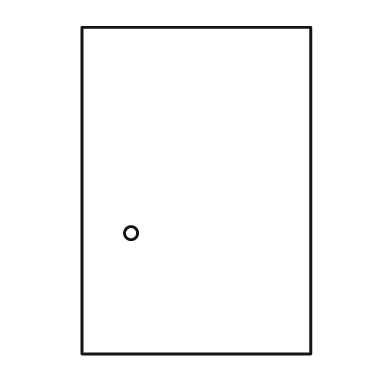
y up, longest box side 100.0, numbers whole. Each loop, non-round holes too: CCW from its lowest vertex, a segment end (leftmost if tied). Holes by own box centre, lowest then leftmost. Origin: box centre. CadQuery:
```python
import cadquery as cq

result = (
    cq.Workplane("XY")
    .moveTo(-35.0, -50.0)
    .lineTo(35.0, -50.0)
    .lineTo(35.0, 50.0)
    .lineTo(-35.0, 50.0)
    .close()
    .moveTo(-20.0, -13.0)
    .circle(2.0)
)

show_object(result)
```